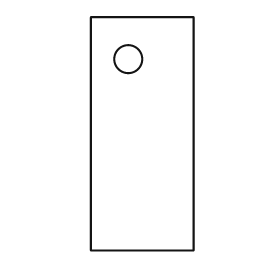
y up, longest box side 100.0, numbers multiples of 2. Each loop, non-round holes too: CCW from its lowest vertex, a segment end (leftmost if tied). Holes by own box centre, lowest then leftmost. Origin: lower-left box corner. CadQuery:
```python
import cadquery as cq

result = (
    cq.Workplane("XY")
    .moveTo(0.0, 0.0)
    .lineTo(44.0, 0.0)
    .lineTo(44.0, 100.0)
    .lineTo(0.0, 100.0)
    .close()
    .moveTo(16.0, 82.0)
    .circle(6.0)
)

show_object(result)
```